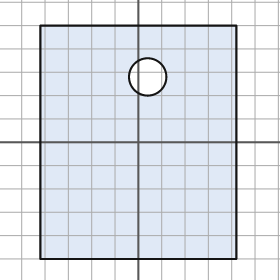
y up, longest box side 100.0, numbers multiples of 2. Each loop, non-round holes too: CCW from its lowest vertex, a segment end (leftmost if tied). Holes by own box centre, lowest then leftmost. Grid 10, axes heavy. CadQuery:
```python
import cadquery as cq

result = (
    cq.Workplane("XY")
    .moveTo(-42.0, -50.0)
    .lineTo(42.0, -50.0)
    .lineTo(42.0, 50.0)
    .lineTo(-42.0, 50.0)
    .close()
    .moveTo(4.0, 28.0)
    .circle(8.0)
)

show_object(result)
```